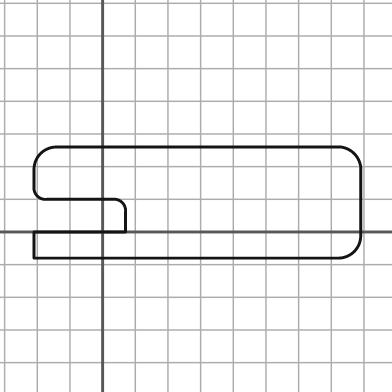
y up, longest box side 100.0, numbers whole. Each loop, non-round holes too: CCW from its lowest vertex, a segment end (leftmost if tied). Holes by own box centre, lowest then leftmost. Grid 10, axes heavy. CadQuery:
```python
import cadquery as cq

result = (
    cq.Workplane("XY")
    .moveTo(-21.0, -8.0)
    .lineTo(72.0, -8.0)
    .threePointArc((77.0, -6.0), (79.0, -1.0))
    .lineTo(79.0, 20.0)
    .threePointArc((77.0, 24.0), (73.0, 26.0))
    .lineTo(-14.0, 26.0)
    .threePointArc((-19.0, 24.0), (-21.0, 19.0))
    .lineTo(-21.0, 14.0)
    .threePointArc((-20.0, 11.0), (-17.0, 10.0))
    .lineTo(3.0, 10.0)
    .threePointArc((6.0, 9.0), (7.0, 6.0))
    .lineTo(7.0, 0.0)
    .lineTo(-21.0, 0.0)
    .close()
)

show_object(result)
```